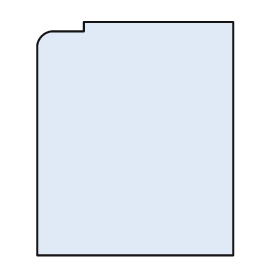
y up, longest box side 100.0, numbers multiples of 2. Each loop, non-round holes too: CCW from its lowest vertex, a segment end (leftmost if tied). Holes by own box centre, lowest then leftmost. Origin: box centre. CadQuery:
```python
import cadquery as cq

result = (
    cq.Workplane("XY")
    .moveTo(-42.0, -50.0)
    .lineTo(42.0, -50.0)
    .lineTo(42.0, 50.0)
    .lineTo(-22.0, 50.0)
    .lineTo(-22.0, 46.0)
    .lineTo(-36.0, 46.0)
    .threePointArc((-40.0, 44.0), (-42.0, 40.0))
    .close()
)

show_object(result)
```